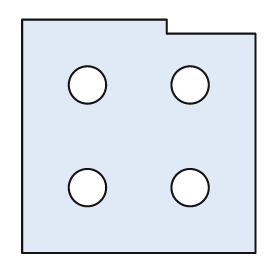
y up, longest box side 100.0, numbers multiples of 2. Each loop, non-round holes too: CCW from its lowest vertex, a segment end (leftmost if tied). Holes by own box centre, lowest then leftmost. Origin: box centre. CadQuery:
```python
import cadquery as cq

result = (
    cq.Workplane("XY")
    .moveTo(-50.0, -50.0)
    .lineTo(50.0, -50.0)
    .lineTo(50.0, 44.0)
    .lineTo(12.0, 44.0)
    .lineTo(12.0, 50.0)
    .lineTo(-50.0, 50.0)
    .close()
    .moveTo(-22.0, -22.0)
    .circle(8.0)
    .moveTo(22.0, -22.0)
    .circle(8.0)
    .moveTo(-22.0, 22.0)
    .circle(8.0)
    .moveTo(22.0, 22.0)
    .circle(8.0)
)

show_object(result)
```